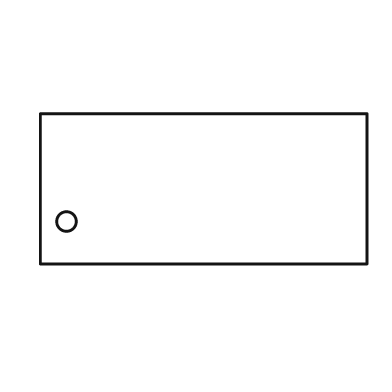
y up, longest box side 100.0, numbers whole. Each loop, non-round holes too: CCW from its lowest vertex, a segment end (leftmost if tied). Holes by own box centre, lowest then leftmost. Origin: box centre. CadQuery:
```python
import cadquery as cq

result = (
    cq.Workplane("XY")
    .moveTo(-50.0, -23.0)
    .lineTo(50.0, -23.0)
    .lineTo(50.0, 23.0)
    .lineTo(-50.0, 23.0)
    .close()
    .moveTo(-42.0, -10.0)
    .circle(3.0)
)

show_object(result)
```